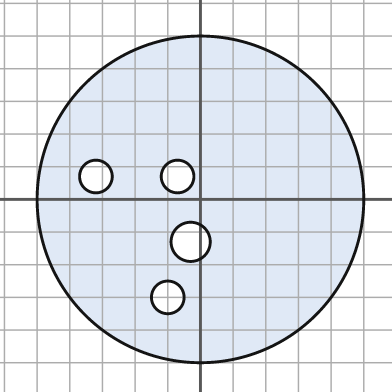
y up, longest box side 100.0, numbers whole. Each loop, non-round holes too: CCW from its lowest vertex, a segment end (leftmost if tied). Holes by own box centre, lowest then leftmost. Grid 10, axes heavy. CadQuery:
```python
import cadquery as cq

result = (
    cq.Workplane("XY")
    .moveTo(0.0, 0.0)
    .circle(50.0)
    .moveTo(-10.0, -30.0)
    .circle(5.0)
    .moveTo(-3.0, -13.0)
    .circle(6.0)
    .moveTo(-32.0, 7.0)
    .circle(5.0)
    .moveTo(-7.0, 7.0)
    .circle(5.0)
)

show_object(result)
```